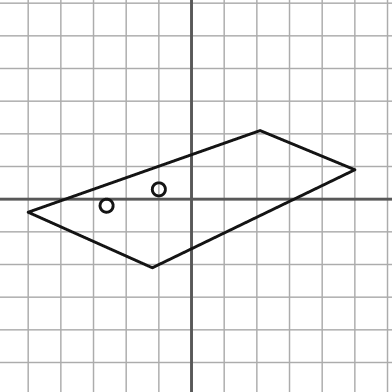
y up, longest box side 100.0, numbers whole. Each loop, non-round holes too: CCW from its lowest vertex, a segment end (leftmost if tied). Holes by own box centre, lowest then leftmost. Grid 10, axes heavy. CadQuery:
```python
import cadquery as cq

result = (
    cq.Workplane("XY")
    .moveTo(-12.0, -21.0)
    .lineTo(50.0, 9.0)
    .lineTo(21.0, 21.0)
    .lineTo(-50.0, -4.0)
    .close()
    .moveTo(-26.0, -2.0)
    .circle(2.0)
    .moveTo(-10.0, 3.0)
    .circle(2.0)
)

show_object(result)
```